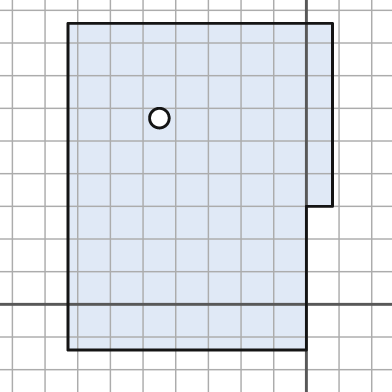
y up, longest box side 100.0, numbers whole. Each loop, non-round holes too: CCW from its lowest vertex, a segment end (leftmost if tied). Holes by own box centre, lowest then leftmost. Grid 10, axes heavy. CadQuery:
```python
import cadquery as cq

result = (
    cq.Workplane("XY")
    .moveTo(-73.0, -14.0)
    .lineTo(0.0, -14.0)
    .lineTo(0.0, 30.0)
    .lineTo(8.0, 30.0)
    .lineTo(8.0, 86.0)
    .lineTo(-73.0, 86.0)
    .close()
    .moveTo(-45.0, 57.0)
    .circle(3.0)
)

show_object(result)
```